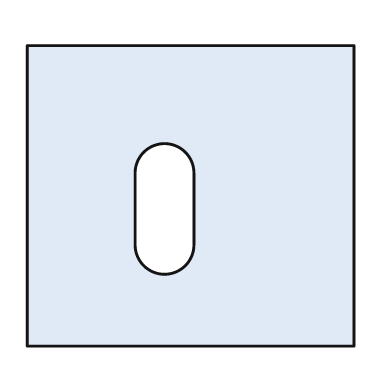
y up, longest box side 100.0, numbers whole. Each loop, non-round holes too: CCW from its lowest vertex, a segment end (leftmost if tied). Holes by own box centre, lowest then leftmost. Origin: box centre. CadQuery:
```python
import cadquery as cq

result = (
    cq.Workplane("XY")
    .moveTo(-50.0, -46.0)
    .lineTo(50.0, -46.0)
    .lineTo(50.0, 46.0)
    .lineTo(-50.0, 46.0)
    .close()
    .moveTo(-17.0, -15.0)
    .threePointArc((-8.0, -24.0), (1.0, -15.0))
    .lineTo(1.0, 7.0)
    .threePointArc((-8.0, 16.0), (-17.0, 7.0))
    .close()
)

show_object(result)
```